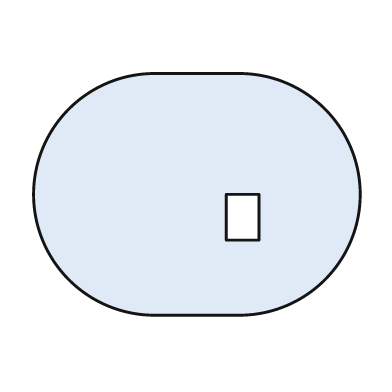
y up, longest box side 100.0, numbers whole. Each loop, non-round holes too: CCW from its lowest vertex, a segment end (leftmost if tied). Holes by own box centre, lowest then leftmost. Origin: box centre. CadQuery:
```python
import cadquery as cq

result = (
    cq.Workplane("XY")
    .moveTo(-13.0, -37.0)
    .lineTo(13.0, -37.0)
    .threePointArc((50.0, 0.0), (13.0, 37.0))
    .lineTo(-13.0, 37.0)
    .threePointArc((-50.0, 0.0), (-13.0, -37.0))
    .close()
    .moveTo(9.0, -14.0)
    .lineTo(19.0, -14.0)
    .lineTo(19.0, 0.0)
    .lineTo(9.0, 0.0)
    .close()
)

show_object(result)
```